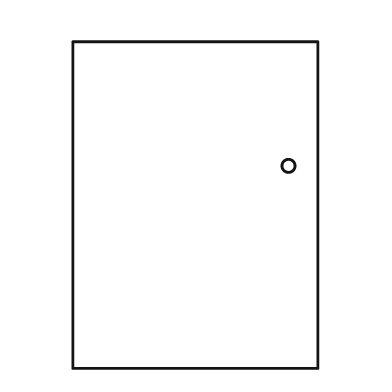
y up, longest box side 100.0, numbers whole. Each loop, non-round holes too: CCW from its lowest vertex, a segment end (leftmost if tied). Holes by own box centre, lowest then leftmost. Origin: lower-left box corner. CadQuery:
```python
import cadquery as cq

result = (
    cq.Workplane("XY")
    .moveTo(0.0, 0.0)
    .lineTo(75.0, 0.0)
    .lineTo(75.0, 100.0)
    .lineTo(0.0, 100.0)
    .close()
    .moveTo(66.0, 62.0)
    .circle(2.0)
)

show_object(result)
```